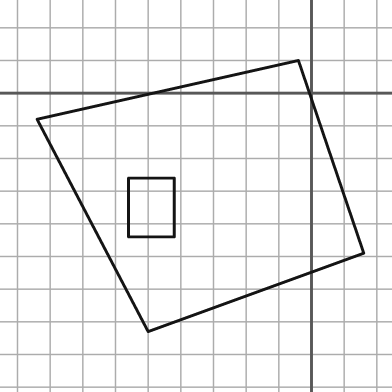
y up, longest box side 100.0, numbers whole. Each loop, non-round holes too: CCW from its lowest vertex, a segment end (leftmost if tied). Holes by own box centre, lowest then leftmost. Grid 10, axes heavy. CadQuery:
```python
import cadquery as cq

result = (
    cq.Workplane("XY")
    .moveTo(-50.0, -73.0)
    .lineTo(16.0, -49.0)
    .lineTo(-4.0, 10.0)
    .lineTo(-84.0, -8.0)
    .close()
    .moveTo(-56.0, -44.0)
    .lineTo(-42.0, -44.0)
    .lineTo(-42.0, -26.0)
    .lineTo(-56.0, -26.0)
    .close()
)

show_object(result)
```